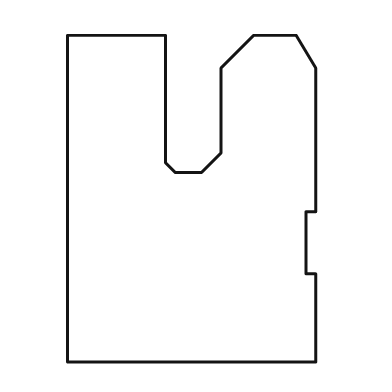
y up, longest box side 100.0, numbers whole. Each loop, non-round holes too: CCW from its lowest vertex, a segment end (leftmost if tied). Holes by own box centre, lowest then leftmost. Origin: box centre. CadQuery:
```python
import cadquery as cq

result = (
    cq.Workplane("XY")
    .moveTo(-38.0, -50.0)
    .lineTo(38.0, -50.0)
    .lineTo(38.0, -23.0)
    .lineTo(35.0, -23.0)
    .lineTo(35.0, -4.0)
    .lineTo(38.0, -4.0)
    .lineTo(38.0, 40.0)
    .lineTo(32.0, 50.0)
    .lineTo(19.0, 50.0)
    .lineTo(9.0, 40.0)
    .lineTo(9.0, 14.0)
    .lineTo(3.0, 8.0)
    .lineTo(-5.0, 8.0)
    .lineTo(-8.0, 11.0)
    .lineTo(-8.0, 50.0)
    .lineTo(-38.0, 50.0)
    .close()
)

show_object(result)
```